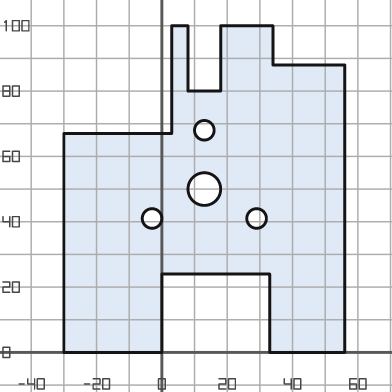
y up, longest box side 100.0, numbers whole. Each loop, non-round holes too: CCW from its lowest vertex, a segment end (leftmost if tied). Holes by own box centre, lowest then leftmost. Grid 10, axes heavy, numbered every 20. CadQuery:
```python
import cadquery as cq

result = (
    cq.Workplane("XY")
    .moveTo(-30.0, 0.0)
    .lineTo(0.0, 0.0)
    .lineTo(0.0, 24.0)
    .lineTo(33.0, 24.0)
    .lineTo(33.0, 0.0)
    .lineTo(56.0, 0.0)
    .lineTo(56.0, 88.0)
    .lineTo(34.0, 88.0)
    .lineTo(34.0, 100.0)
    .lineTo(18.0, 100.0)
    .lineTo(18.0, 80.0)
    .lineTo(8.0, 80.0)
    .lineTo(8.0, 100.0)
    .lineTo(3.0, 100.0)
    .lineTo(3.0, 67.0)
    .lineTo(-30.0, 67.0)
    .close()
    .moveTo(-3.0, 41.0)
    .circle(3.0)
    .moveTo(29.0, 41.0)
    .circle(3.0)
    .moveTo(13.0, 50.0)
    .circle(5.0)
    .moveTo(13.0, 68.0)
    .circle(3.0)
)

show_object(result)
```